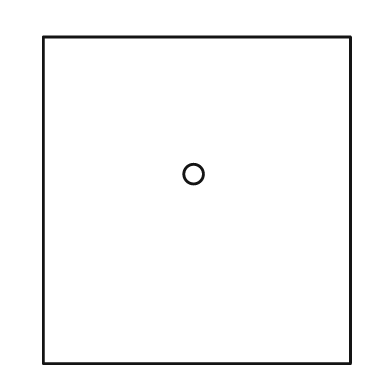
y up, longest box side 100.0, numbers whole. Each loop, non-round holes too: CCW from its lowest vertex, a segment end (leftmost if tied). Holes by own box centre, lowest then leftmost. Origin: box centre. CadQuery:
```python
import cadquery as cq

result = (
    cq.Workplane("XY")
    .moveTo(-47.0, -50.0)
    .lineTo(47.0, -50.0)
    .lineTo(47.0, 50.0)
    .lineTo(-47.0, 50.0)
    .close()
    .moveTo(-1.0, 8.0)
    .circle(3.0)
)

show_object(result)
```